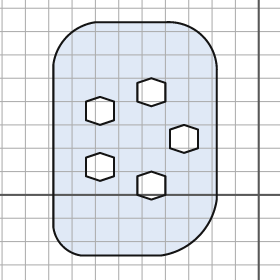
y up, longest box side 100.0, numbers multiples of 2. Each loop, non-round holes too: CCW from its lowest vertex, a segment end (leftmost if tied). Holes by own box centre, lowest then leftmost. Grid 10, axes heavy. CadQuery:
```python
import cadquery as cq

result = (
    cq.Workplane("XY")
    .moveTo(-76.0, -26.0)
    .lineTo(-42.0, -26.0)
    .threePointArc((-26.0, -18.0), (-18.0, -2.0))
    .lineTo(-18.0, 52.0)
    .threePointArc((-24.0, 68.0), (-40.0, 74.0))
    .lineTo(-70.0, 74.0)
    .threePointArc((-82.0, 68.0), (-88.0, 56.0))
    .lineTo(-88.0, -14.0)
    .threePointArc((-84.0, -22.0), (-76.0, -26.0))
    .close()
    .moveTo(-46.0, -2.0)
    .lineTo(-40.0, 0.0)
    .lineTo(-40.0, 8.0)
    .lineTo(-46.0, 10.0)
    .lineTo(-52.0, 8.0)
    .lineTo(-52.0, 0.0)
    .close()
    .moveTo(-68.0, 6.0)
    .lineTo(-62.0, 8.0)
    .lineTo(-62.0, 16.0)
    .lineTo(-68.0, 18.0)
    .lineTo(-74.0, 16.0)
    .lineTo(-74.0, 8.0)
    .close()
    .moveTo(-32.0, 18.0)
    .lineTo(-26.0, 20.0)
    .lineTo(-26.0, 28.0)
    .lineTo(-32.0, 30.0)
    .lineTo(-38.0, 28.0)
    .lineTo(-38.0, 20.0)
    .close()
    .moveTo(-68.0, 30.0)
    .lineTo(-62.0, 32.0)
    .lineTo(-62.0, 40.0)
    .lineTo(-68.0, 42.0)
    .lineTo(-74.0, 40.0)
    .lineTo(-74.0, 32.0)
    .close()
    .moveTo(-46.0, 38.0)
    .lineTo(-40.0, 40.0)
    .lineTo(-40.0, 48.0)
    .lineTo(-46.0, 50.0)
    .lineTo(-52.0, 48.0)
    .lineTo(-52.0, 40.0)
    .close()
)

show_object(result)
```